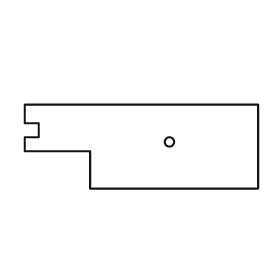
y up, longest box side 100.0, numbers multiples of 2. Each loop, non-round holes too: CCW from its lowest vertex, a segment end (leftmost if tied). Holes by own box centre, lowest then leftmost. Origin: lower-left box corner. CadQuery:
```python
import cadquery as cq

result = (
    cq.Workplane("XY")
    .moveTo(28.0, 0.0)
    .lineTo(100.0, 0.0)
    .lineTo(100.0, 36.0)
    .lineTo(0.0, 36.0)
    .lineTo(0.0, 28.0)
    .lineTo(6.0, 28.0)
    .lineTo(6.0, 22.0)
    .lineTo(0.0, 22.0)
    .lineTo(0.0, 16.0)
    .lineTo(28.0, 16.0)
    .close()
    .moveTo(62.0, 20.0)
    .circle(2.0)
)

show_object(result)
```